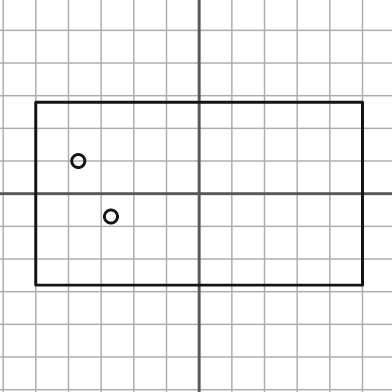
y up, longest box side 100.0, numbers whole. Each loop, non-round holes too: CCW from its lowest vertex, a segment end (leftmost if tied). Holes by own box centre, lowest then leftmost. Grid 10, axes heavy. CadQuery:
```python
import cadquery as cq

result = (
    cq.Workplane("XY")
    .moveTo(-50.0, -28.0)
    .lineTo(50.0, -28.0)
    .lineTo(50.0, 28.0)
    .lineTo(-50.0, 28.0)
    .close()
    .moveTo(-27.0, -7.0)
    .circle(2.0)
    .moveTo(-37.0, 10.0)
    .circle(2.0)
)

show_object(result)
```